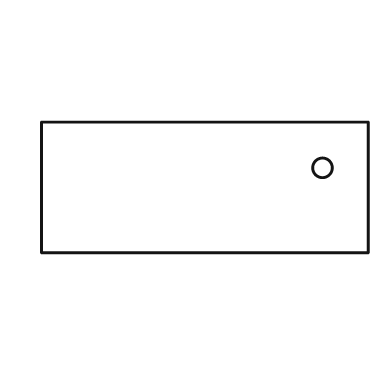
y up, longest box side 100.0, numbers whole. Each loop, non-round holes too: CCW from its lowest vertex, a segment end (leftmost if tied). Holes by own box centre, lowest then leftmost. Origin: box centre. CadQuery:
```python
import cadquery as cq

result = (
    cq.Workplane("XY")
    .moveTo(-50.0, -20.0)
    .lineTo(50.0, -20.0)
    .lineTo(50.0, 20.0)
    .lineTo(-50.0, 20.0)
    .close()
    .moveTo(36.0, 6.0)
    .circle(3.0)
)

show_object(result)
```